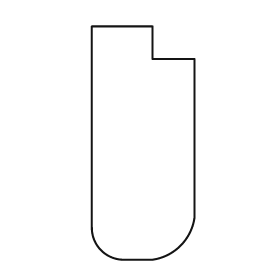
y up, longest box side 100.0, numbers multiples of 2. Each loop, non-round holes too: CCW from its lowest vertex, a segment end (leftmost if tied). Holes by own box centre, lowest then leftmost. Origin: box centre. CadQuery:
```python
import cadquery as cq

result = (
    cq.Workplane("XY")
    .moveTo(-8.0, -50.0)
    .lineTo(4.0, -50.0)
    .threePointArc((16.0, -44.0), (22.0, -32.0))
    .lineTo(22.0, 36.0)
    .lineTo(4.0, 36.0)
    .lineTo(4.0, 50.0)
    .lineTo(-22.0, 50.0)
    .lineTo(-22.0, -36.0)
    .threePointArc((-18.0, -46.0), (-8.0, -50.0))
    .close()
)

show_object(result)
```